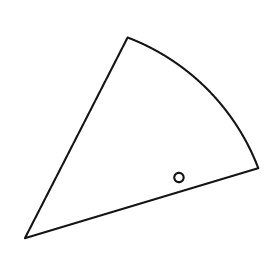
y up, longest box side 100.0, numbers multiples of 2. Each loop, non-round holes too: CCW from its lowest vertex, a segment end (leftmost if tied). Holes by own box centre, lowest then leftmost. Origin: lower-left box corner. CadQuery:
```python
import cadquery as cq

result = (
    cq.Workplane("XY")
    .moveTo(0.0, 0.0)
    .lineTo(100.0, 30.0)
    .threePointArc((78.0, 64.0), (44.0, 86.0))
    .close()
    .moveTo(66.0, 26.0)
    .circle(2.0)
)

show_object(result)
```